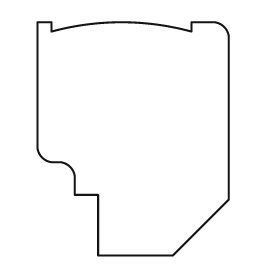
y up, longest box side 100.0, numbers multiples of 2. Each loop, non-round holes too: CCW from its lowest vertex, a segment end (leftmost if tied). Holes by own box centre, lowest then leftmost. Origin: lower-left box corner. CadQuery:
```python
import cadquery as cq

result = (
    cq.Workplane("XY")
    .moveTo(26.0, 0.0)
    .lineTo(58.0, 0.0)
    .lineTo(82.0, 24.0)
    .lineTo(82.0, 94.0)
    .threePointArc((80.0, 98.0), (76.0, 100.0))
    .lineTo(66.0, 100.0)
    .lineTo(66.0, 96.0)
    .threePointArc((36.0, 100.0), (6.0, 96.0))
    .lineTo(6.0, 100.0)
    .lineTo(0.0, 100.0)
    .lineTo(0.0, 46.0)
    .threePointArc((2.0, 42.0), (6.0, 40.0))
    .lineTo(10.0, 40.0)
    .threePointArc((14.0, 38.0), (16.0, 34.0))
    .lineTo(16.0, 26.0)
    .lineTo(26.0, 26.0)
    .close()
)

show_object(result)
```